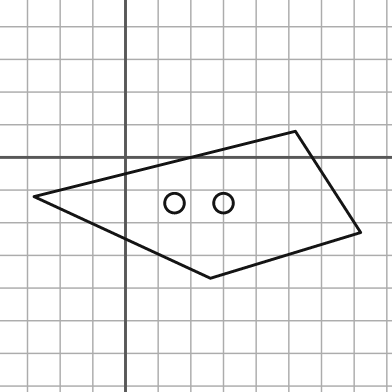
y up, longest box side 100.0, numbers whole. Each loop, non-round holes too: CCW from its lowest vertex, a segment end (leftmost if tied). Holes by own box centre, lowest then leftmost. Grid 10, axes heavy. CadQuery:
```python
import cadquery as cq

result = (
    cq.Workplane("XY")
    .moveTo(26.0, -37.0)
    .lineTo(72.0, -23.0)
    .lineTo(52.0, 8.0)
    .lineTo(-28.0, -12.0)
    .close()
    .moveTo(15.0, -14.0)
    .circle(3.0)
    .moveTo(30.0, -14.0)
    .circle(3.0)
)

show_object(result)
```